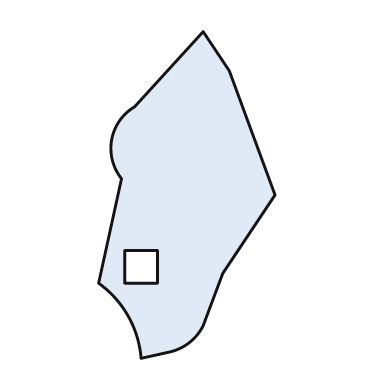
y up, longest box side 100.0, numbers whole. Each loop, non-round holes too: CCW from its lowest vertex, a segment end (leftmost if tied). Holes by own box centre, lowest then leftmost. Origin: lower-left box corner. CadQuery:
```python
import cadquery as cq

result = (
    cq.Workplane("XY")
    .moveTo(13.0, 0.0)
    .lineTo(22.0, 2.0)
    .threePointArc((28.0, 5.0), (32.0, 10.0))
    .lineTo(38.0, 26.0)
    .lineTo(54.0, 50.0)
    .lineTo(40.0, 88.0)
    .lineTo(32.0, 100.0)
    .lineTo(11.0, 77.0)
    .threePointArc((4.0, 67.0), (7.0, 55.0))
    .lineTo(0.0, 23.0)
    .threePointArc((9.0, 13.0), (13.0, 0.0))
    .close()
    .moveTo(8.0, 23.0)
    .lineTo(18.0, 23.0)
    .lineTo(18.0, 33.0)
    .lineTo(8.0, 33.0)
    .close()
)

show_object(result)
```